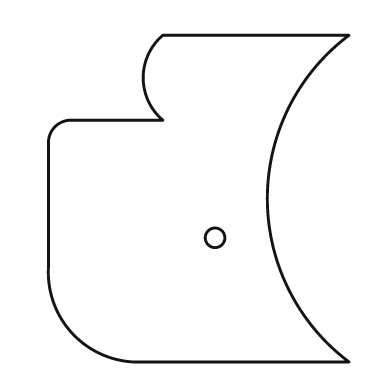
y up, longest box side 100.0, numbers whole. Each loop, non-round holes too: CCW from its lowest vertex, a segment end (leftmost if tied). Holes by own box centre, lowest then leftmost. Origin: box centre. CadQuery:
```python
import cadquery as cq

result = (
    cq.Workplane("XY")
    .moveTo(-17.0, -50.0)
    .lineTo(46.0, -50.0)
    .threePointArc((21.0, 0.0), (46.0, 50.0))
    .lineTo(-11.0, 50.0)
    .threePointArc((-17.0, 37.0), (-11.0, 24.0))
    .lineTo(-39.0, 24.0)
    .threePointArc((-44.0, 22.0), (-46.0, 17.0))
    .lineTo(-46.0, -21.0)
    .threePointArc((-38.0, -42.0), (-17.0, -50.0))
    .close()
    .moveTo(5.0, -12.0)
    .circle(3.0)
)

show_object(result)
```